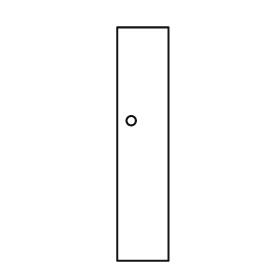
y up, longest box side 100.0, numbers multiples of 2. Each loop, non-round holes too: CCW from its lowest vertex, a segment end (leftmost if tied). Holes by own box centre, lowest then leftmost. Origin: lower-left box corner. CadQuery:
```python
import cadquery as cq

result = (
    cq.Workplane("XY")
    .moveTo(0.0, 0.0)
    .lineTo(22.0, 0.0)
    .lineTo(22.0, 100.0)
    .lineTo(0.0, 100.0)
    .close()
    .moveTo(6.0, 60.0)
    .circle(2.0)
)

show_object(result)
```